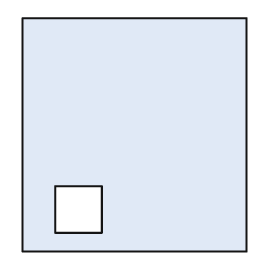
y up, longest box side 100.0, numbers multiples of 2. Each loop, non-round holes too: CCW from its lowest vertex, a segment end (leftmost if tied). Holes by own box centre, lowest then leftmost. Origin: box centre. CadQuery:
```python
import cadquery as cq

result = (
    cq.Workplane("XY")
    .moveTo(-48.0, -50.0)
    .lineTo(48.0, -50.0)
    .lineTo(48.0, 50.0)
    .lineTo(-48.0, 50.0)
    .close()
    .moveTo(-34.0, -42.0)
    .lineTo(-14.0, -42.0)
    .lineTo(-14.0, -22.0)
    .lineTo(-34.0, -22.0)
    .close()
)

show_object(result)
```